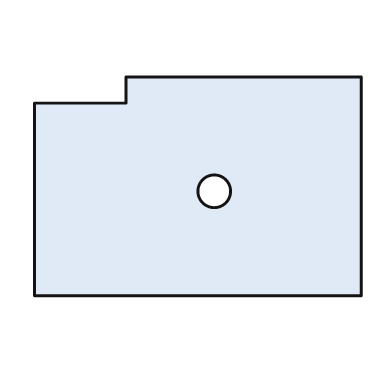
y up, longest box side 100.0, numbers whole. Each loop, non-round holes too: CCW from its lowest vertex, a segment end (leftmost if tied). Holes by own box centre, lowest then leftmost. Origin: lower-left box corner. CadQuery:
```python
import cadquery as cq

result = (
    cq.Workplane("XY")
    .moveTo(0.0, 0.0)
    .lineTo(100.0, 0.0)
    .lineTo(100.0, 67.0)
    .lineTo(28.0, 67.0)
    .lineTo(28.0, 59.0)
    .lineTo(0.0, 59.0)
    .close()
    .moveTo(55.0, 32.0)
    .circle(5.0)
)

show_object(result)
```